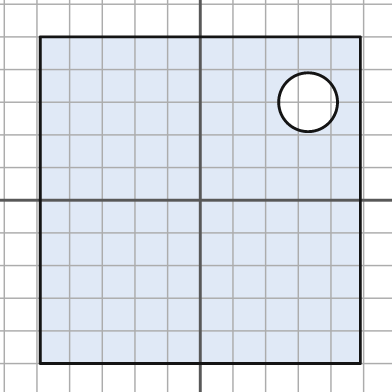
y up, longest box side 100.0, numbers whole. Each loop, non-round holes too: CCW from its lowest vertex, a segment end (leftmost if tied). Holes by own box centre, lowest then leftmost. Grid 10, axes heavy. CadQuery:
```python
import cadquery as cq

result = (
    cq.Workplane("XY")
    .moveTo(-49.0, -50.0)
    .lineTo(49.0, -50.0)
    .lineTo(49.0, 50.0)
    .lineTo(-49.0, 50.0)
    .close()
    .moveTo(33.0, 30.0)
    .circle(9.0)
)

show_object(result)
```